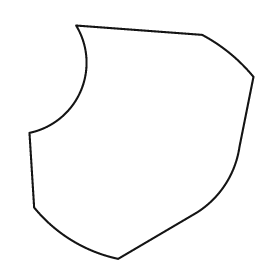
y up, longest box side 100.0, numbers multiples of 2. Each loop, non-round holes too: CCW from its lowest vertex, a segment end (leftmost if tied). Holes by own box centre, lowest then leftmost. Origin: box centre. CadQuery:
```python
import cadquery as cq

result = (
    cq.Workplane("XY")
    .moveTo(-10.0, -50.0)
    .lineTo(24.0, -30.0)
    .threePointArc((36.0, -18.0), (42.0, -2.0))
    .lineTo(48.0, 28.0)
    .threePointArc((38.0, 38.0), (26.0, 46.0))
    .lineTo(-28.0, 50.0)
    .threePointArc((-26.0, 22.0), (-48.0, 4.0))
    .lineTo(-46.0, -28.0)
    .threePointArc((-30.0, -42.0), (-10.0, -50.0))
    .close()
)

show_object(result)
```